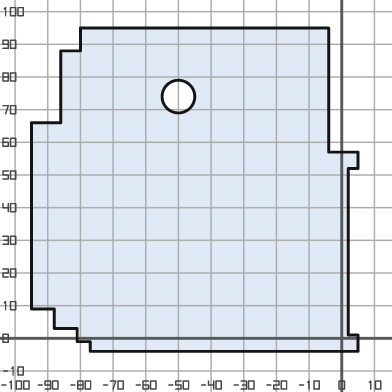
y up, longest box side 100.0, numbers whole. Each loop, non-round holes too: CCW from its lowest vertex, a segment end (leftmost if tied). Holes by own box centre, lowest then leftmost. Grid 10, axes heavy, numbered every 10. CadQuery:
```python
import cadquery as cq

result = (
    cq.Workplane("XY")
    .moveTo(-77.0, -4.0)
    .lineTo(5.0, -4.0)
    .lineTo(5.0, 1.0)
    .lineTo(2.0, 1.0)
    .lineTo(2.0, 52.0)
    .lineTo(5.0, 52.0)
    .lineTo(5.0, 57.0)
    .lineTo(-4.0, 57.0)
    .lineTo(-4.0, 95.0)
    .lineTo(-80.0, 95.0)
    .lineTo(-80.0, 88.0)
    .lineTo(-86.0, 88.0)
    .lineTo(-86.0, 66.0)
    .lineTo(-95.0, 66.0)
    .lineTo(-95.0, 9.0)
    .lineTo(-88.0, 9.0)
    .lineTo(-88.0, 3.0)
    .lineTo(-81.0, 3.0)
    .lineTo(-81.0, -1.0)
    .lineTo(-77.0, -1.0)
    .close()
    .moveTo(-50.0, 74.0)
    .circle(5.0)
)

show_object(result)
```